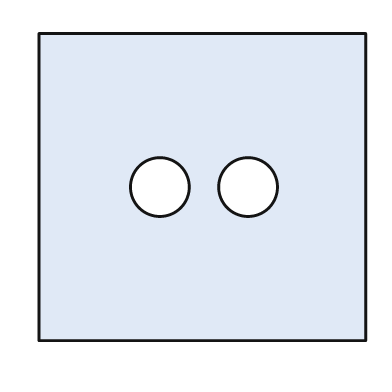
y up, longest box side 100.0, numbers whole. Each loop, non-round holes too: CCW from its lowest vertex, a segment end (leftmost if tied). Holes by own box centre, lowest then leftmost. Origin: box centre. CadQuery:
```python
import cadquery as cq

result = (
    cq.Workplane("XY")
    .moveTo(-50.0, -47.0)
    .lineTo(50.0, -47.0)
    .lineTo(50.0, 47.0)
    .lineTo(-50.0, 47.0)
    .close()
    .moveTo(-13.0, 0.0)
    .circle(9.0)
    .moveTo(14.0, 0.0)
    .circle(9.0)
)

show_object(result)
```